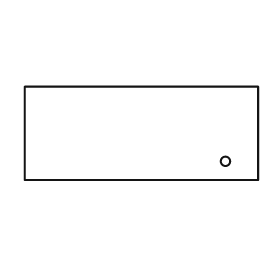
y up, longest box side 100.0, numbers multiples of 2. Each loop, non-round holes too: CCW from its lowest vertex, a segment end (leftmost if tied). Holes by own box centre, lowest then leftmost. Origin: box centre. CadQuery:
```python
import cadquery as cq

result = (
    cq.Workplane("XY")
    .moveTo(-50.0, -20.0)
    .lineTo(50.0, -20.0)
    .lineTo(50.0, 20.0)
    .lineTo(-50.0, 20.0)
    .close()
    .moveTo(36.0, -12.0)
    .circle(2.0)
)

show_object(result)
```